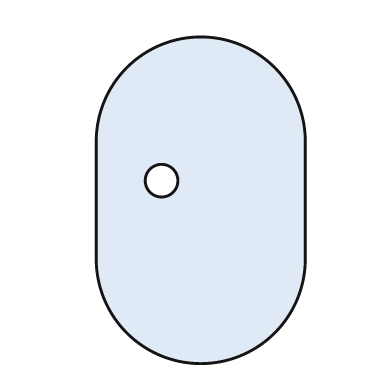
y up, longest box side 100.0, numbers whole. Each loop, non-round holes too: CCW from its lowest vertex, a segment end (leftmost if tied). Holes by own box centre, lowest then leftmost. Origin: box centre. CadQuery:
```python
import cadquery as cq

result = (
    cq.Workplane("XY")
    .moveTo(-32.0, -18.0)
    .threePointArc((0.0, -50.0), (32.0, -18.0))
    .lineTo(32.0, 18.0)
    .threePointArc((0.0, 50.0), (-32.0, 18.0))
    .close()
    .moveTo(-12.0, 6.0)
    .circle(5.0)
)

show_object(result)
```